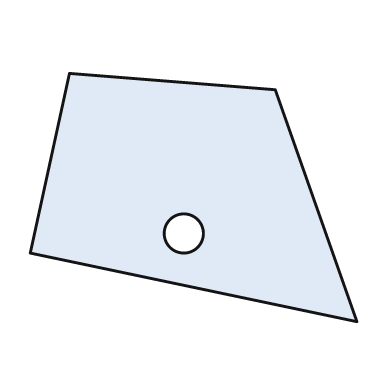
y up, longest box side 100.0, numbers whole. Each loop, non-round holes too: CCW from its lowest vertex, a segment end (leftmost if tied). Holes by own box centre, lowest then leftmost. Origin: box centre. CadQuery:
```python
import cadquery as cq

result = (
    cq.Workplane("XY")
    .moveTo(50.0, -38.0)
    .lineTo(25.0, 33.0)
    .lineTo(-38.0, 38.0)
    .lineTo(-50.0, -17.0)
    .close()
    .moveTo(-3.0, -11.0)
    .circle(6.0)
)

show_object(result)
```